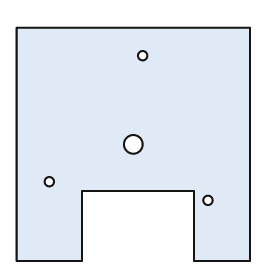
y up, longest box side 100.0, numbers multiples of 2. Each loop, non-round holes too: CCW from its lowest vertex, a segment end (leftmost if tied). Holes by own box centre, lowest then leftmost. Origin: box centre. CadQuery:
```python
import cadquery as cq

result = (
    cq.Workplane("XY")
    .moveTo(-50.0, -50.0)
    .lineTo(-22.0, -50.0)
    .lineTo(-22.0, -20.0)
    .lineTo(26.0, -20.0)
    .lineTo(26.0, -50.0)
    .lineTo(50.0, -50.0)
    .lineTo(50.0, 50.0)
    .lineTo(-50.0, 50.0)
    .close()
    .moveTo(32.0, -24.0)
    .circle(2.0)
    .moveTo(-36.0, -16.0)
    .circle(2.0)
    .moveTo(0.0, 0.0)
    .circle(4.0)
    .moveTo(4.0, 38.0)
    .circle(2.0)
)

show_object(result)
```